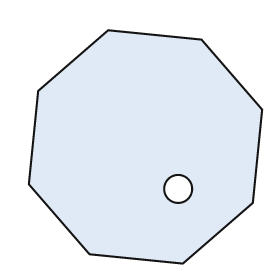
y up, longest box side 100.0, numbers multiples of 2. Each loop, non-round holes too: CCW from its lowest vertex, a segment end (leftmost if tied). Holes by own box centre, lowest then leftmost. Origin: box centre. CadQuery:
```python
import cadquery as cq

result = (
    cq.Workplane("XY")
    .moveTo(16.0, -50.0)
    .lineTo(46.0, -24.0)
    .lineTo(50.0, 16.0)
    .lineTo(24.0, 46.0)
    .lineTo(-16.0, 50.0)
    .lineTo(-46.0, 24.0)
    .lineTo(-50.0, -16.0)
    .lineTo(-24.0, -46.0)
    .close()
    .moveTo(14.0, -18.0)
    .circle(6.0)
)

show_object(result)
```